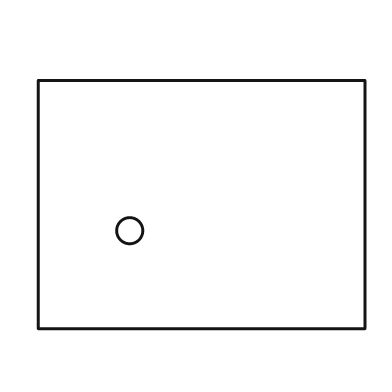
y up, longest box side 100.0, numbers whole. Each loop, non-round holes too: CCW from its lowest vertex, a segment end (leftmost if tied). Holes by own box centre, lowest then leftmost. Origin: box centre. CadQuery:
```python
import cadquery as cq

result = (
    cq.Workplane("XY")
    .moveTo(-50.0, -38.0)
    .lineTo(50.0, -38.0)
    .lineTo(50.0, 38.0)
    .lineTo(-50.0, 38.0)
    .close()
    .moveTo(-22.0, -8.0)
    .circle(4.0)
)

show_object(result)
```